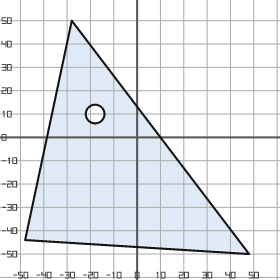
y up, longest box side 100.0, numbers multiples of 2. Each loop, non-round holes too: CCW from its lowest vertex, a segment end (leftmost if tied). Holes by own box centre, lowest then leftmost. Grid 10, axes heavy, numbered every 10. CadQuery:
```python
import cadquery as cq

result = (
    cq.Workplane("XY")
    .moveTo(48.0, -50.0)
    .lineTo(-28.0, 50.0)
    .lineTo(-48.0, -44.0)
    .close()
    .moveTo(-18.0, 10.0)
    .circle(4.0)
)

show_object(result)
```